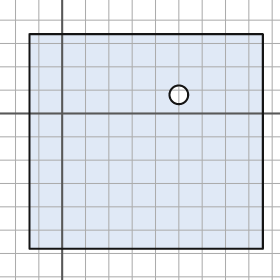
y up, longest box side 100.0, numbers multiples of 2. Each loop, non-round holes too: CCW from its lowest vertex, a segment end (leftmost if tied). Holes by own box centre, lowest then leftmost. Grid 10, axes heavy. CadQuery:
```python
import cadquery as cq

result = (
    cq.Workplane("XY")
    .moveTo(-14.0, -58.0)
    .lineTo(86.0, -58.0)
    .lineTo(86.0, 34.0)
    .lineTo(-14.0, 34.0)
    .close()
    .moveTo(50.0, 8.0)
    .circle(4.0)
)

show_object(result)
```